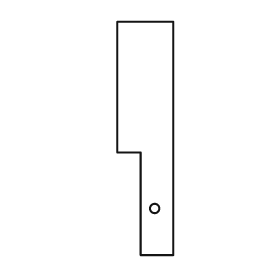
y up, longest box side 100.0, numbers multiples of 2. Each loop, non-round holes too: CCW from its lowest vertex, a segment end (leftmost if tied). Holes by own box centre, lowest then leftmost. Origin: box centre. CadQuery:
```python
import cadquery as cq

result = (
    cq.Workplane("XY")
    .moveTo(-2.0, -50.0)
    .lineTo(12.0, -50.0)
    .lineTo(12.0, 50.0)
    .lineTo(-12.0, 50.0)
    .lineTo(-12.0, -6.0)
    .lineTo(-2.0, -6.0)
    .close()
    .moveTo(4.0, -30.0)
    .circle(2.0)
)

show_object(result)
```